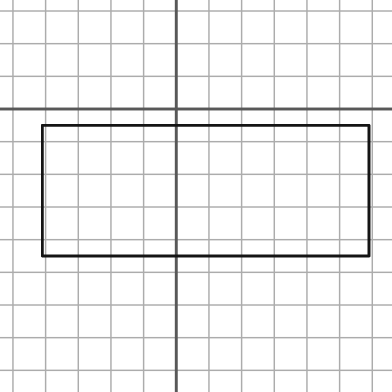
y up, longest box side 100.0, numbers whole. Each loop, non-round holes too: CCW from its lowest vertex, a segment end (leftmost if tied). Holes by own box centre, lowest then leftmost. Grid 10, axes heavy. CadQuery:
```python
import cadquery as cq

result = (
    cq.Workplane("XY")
    .moveTo(-41.0, -45.0)
    .lineTo(59.0, -45.0)
    .lineTo(59.0, -5.0)
    .lineTo(-41.0, -5.0)
    .close()
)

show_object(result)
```